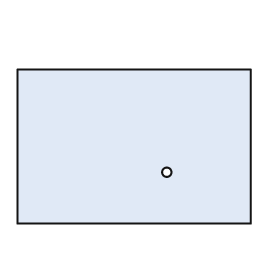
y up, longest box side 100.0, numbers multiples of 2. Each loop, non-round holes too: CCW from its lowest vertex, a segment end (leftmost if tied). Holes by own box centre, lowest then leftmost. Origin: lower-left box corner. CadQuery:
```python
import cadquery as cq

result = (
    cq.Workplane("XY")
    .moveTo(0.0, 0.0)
    .lineTo(100.0, 0.0)
    .lineTo(100.0, 66.0)
    .lineTo(0.0, 66.0)
    .close()
    .moveTo(64.0, 22.0)
    .circle(2.0)
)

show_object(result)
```